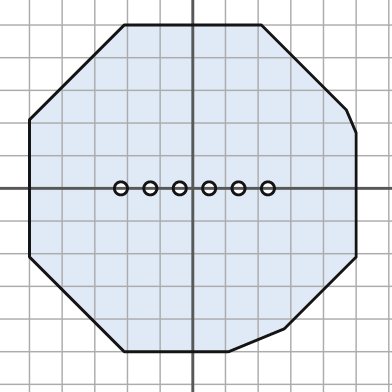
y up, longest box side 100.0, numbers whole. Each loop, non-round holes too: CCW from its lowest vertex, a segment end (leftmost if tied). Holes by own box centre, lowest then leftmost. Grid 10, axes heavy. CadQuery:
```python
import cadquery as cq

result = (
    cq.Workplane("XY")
    .moveTo(-21.0, -50.0)
    .lineTo(11.0, -50.0)
    .lineTo(28.0, -43.0)
    .lineTo(50.0, -21.0)
    .lineTo(50.0, 17.0)
    .lineTo(47.0, 24.0)
    .lineTo(21.0, 50.0)
    .lineTo(-21.0, 50.0)
    .lineTo(-50.0, 21.0)
    .lineTo(-50.0, -21.0)
    .close()
    .moveTo(-22.0, 0.0)
    .circle(2.0)
    .moveTo(-13.0, 0.0)
    .circle(2.0)
    .moveTo(-4.0, 0.0)
    .circle(2.0)
    .moveTo(5.0, 0.0)
    .circle(2.0)
    .moveTo(14.0, 0.0)
    .circle(2.0)
    .moveTo(23.0, 0.0)
    .circle(2.0)
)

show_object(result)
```